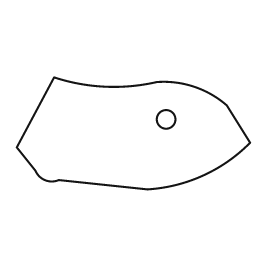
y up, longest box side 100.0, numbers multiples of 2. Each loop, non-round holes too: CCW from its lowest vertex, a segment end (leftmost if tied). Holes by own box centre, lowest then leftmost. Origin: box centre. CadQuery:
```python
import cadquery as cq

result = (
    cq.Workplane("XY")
    .moveTo(6.0, -24.0)
    .threePointArc((30.0, -18.0), (50.0, -4.0))
    .lineTo(40.0, 12.0)
    .threePointArc((26.0, 20.0), (10.0, 22.0))
    .threePointArc((-12.0, 20.0), (-34.0, 24.0))
    .lineTo(-50.0, -6.0)
    .lineTo(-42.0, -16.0)
    .threePointArc((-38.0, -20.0), (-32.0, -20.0))
    .close()
    .moveTo(14.0, 6.0)
    .circle(4.0)
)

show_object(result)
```